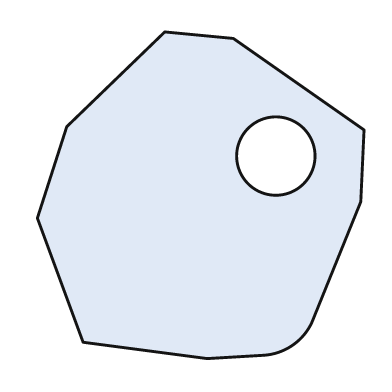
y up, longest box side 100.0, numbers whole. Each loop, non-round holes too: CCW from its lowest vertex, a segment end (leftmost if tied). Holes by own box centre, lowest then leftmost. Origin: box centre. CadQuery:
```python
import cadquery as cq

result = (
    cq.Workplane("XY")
    .moveTo(2.0, -50.0)
    .lineTo(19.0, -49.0)
    .threePointArc((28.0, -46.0), (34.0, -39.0))
    .lineTo(49.0, -2.0)
    .lineTo(50.0, 20.0)
    .lineTo(10.0, 48.0)
    .lineTo(-11.0, 50.0)
    .lineTo(-41.0, 21.0)
    .lineTo(-50.0, -7.0)
    .lineTo(-36.0, -45.0)
    .close()
    .moveTo(23.0, 12.0)
    .circle(12.0)
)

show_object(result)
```